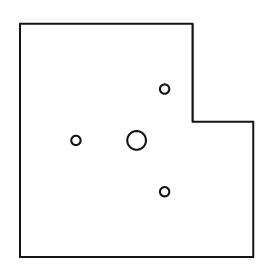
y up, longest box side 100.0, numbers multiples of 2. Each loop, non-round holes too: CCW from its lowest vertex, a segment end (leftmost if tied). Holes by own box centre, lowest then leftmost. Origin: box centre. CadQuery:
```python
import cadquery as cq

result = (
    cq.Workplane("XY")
    .moveTo(-50.0, -50.0)
    .lineTo(50.0, -50.0)
    .lineTo(50.0, 8.0)
    .lineTo(24.0, 8.0)
    .lineTo(24.0, 50.0)
    .lineTo(-50.0, 50.0)
    .close()
    .moveTo(12.0, -22.0)
    .circle(2.0)
    .moveTo(-26.0, 0.0)
    .circle(2.0)
    .moveTo(0.0, 0.0)
    .circle(4.0)
    .moveTo(12.0, 22.0)
    .circle(2.0)
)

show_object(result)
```